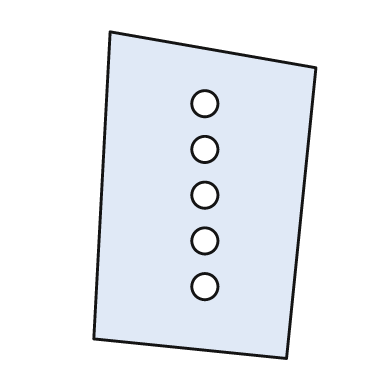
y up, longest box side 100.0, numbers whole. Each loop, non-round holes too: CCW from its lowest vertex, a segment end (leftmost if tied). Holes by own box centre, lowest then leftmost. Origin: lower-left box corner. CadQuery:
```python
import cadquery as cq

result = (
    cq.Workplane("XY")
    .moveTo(59.0, 0.0)
    .lineTo(68.0, 89.0)
    .lineTo(5.0, 100.0)
    .lineTo(0.0, 6.0)
    .close()
    .moveTo(34.0, 22.0)
    .circle(4.0)
    .moveTo(34.0, 36.0)
    .circle(4.0)
    .moveTo(34.0, 50.0)
    .circle(4.0)
    .moveTo(34.0, 64.0)
    .circle(4.0)
    .moveTo(34.0, 78.0)
    .circle(4.0)
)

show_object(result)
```